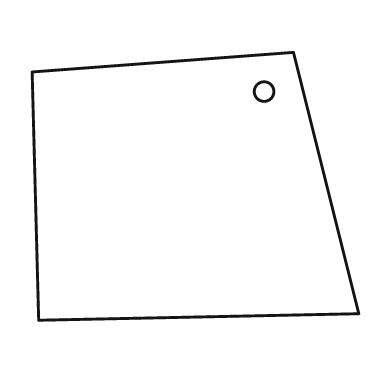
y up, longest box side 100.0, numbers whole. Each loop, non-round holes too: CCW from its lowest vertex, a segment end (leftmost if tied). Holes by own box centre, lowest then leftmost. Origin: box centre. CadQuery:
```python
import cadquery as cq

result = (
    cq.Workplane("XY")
    .moveTo(-48.0, -41.0)
    .lineTo(50.0, -39.0)
    .lineTo(30.0, 41.0)
    .lineTo(-50.0, 35.0)
    .close()
    .moveTo(21.0, 29.0)
    .circle(3.0)
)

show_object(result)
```